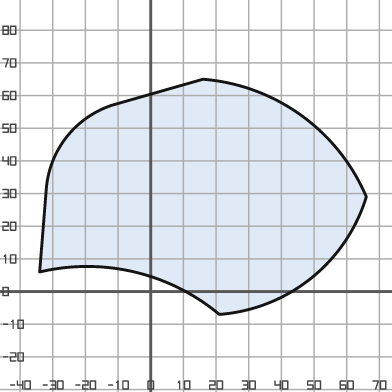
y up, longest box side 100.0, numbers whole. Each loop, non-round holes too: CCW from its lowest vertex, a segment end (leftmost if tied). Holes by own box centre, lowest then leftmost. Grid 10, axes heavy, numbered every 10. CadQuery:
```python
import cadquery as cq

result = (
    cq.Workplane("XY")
    .moveTo(21.0, -7.0)
    .threePointArc((49.0, 4.0), (66.0, 29.0))
    .threePointArc((46.0, 54.0), (16.0, 65.0))
    .lineTo(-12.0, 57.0)
    .threePointArc((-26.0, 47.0), (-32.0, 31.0))
    .lineTo(-34.0, 6.0)
    .threePointArc((-5.0, 6.0), (21.0, -7.0))
    .close()
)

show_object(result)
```